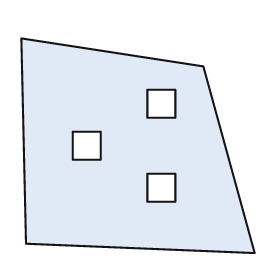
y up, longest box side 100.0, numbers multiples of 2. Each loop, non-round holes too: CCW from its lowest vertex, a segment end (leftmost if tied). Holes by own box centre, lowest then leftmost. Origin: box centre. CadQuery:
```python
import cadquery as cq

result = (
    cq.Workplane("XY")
    .moveTo(50.0, -46.0)
    .lineTo(28.0, 34.0)
    .lineTo(-50.0, 46.0)
    .lineTo(-48.0, -42.0)
    .close()
    .moveTo(4.0, -24.0)
    .lineTo(16.0, -24.0)
    .lineTo(16.0, -12.0)
    .lineTo(4.0, -12.0)
    .close()
    .moveTo(-28.0, -6.0)
    .lineTo(-16.0, -6.0)
    .lineTo(-16.0, 6.0)
    .lineTo(-28.0, 6.0)
    .close()
    .moveTo(4.0, 12.0)
    .lineTo(16.0, 12.0)
    .lineTo(16.0, 24.0)
    .lineTo(4.0, 24.0)
    .close()
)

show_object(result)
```